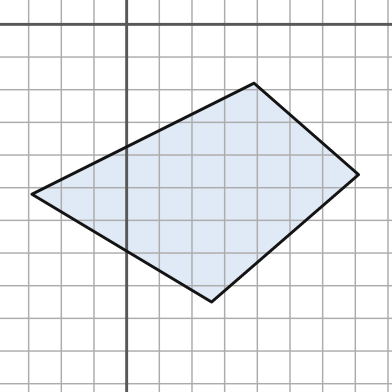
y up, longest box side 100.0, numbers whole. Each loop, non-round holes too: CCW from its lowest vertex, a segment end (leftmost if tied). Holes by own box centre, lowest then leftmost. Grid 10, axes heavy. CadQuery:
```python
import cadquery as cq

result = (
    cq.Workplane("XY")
    .moveTo(26.0, -85.0)
    .lineTo(71.0, -46.0)
    .lineTo(39.0, -18.0)
    .lineTo(-29.0, -52.0)
    .close()
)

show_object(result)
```